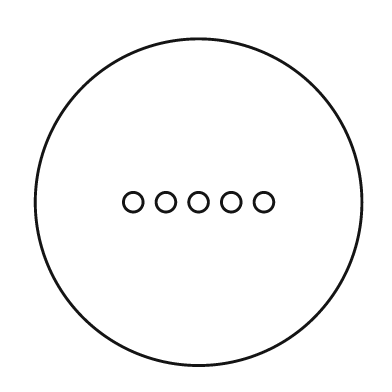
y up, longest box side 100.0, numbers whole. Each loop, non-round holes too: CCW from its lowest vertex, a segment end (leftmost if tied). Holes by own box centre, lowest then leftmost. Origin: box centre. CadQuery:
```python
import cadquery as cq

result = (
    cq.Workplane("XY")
    .moveTo(0.0, 0.0)
    .circle(50.0)
    .moveTo(-20.0, 0.0)
    .circle(3.0)
    .moveTo(-10.0, 0.0)
    .circle(3.0)
    .moveTo(0.0, 0.0)
    .circle(3.0)
    .moveTo(10.0, 0.0)
    .circle(3.0)
    .moveTo(20.0, 0.0)
    .circle(3.0)
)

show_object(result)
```